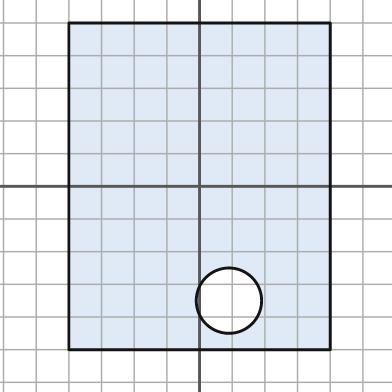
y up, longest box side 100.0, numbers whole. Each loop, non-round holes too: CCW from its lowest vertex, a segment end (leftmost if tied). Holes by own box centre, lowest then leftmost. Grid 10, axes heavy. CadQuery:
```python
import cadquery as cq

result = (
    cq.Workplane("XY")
    .moveTo(-40.0, -50.0)
    .lineTo(40.0, -50.0)
    .lineTo(40.0, 50.0)
    .lineTo(-40.0, 50.0)
    .close()
    .moveTo(9.0, -35.0)
    .circle(10.0)
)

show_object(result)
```